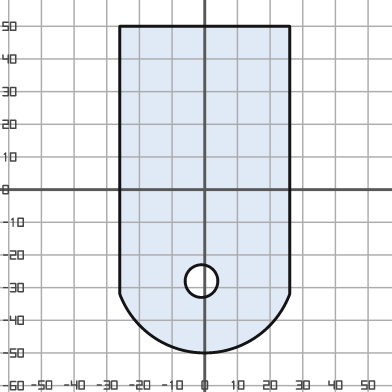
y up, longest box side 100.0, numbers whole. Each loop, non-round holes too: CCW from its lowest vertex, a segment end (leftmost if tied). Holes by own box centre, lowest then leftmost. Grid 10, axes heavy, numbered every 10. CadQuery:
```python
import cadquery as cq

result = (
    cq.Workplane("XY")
    .moveTo(-26.0, -32.0)
    .threePointArc((0.0, -50.0), (26.0, -32.0))
    .lineTo(26.0, 50.0)
    .lineTo(-26.0, 50.0)
    .close()
    .moveTo(-1.0, -28.0)
    .circle(5.0)
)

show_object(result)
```